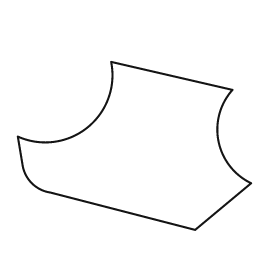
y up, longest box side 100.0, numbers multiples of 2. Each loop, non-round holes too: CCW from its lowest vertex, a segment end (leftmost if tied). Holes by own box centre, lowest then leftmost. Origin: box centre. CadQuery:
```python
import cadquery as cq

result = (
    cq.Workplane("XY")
    .moveTo(26.0, -36.0)
    .lineTo(50.0, -16.0)
    .threePointArc((36.0, 2.0), (42.0, 24.0))
    .lineTo(-10.0, 36.0)
    .threePointArc((-20.0, 8.0), (-50.0, 4.0))
    .lineTo(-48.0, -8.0)
    .threePointArc((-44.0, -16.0), (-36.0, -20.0))
    .close()
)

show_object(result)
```